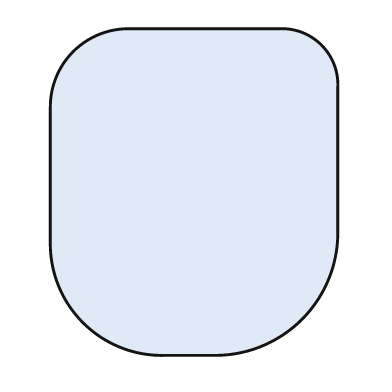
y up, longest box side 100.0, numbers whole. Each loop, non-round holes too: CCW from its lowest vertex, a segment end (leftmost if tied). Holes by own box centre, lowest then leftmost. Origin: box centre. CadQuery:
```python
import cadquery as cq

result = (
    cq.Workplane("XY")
    .moveTo(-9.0, -50.0)
    .lineTo(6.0, -50.0)
    .threePointArc((33.0, -39.0), (44.0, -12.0))
    .lineTo(44.0, 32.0)
    .threePointArc((39.0, 45.0), (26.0, 50.0))
    .lineTo(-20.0, 50.0)
    .threePointArc((-37.0, 43.0), (-44.0, 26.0))
    .lineTo(-44.0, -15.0)
    .threePointArc((-34.0, -40.0), (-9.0, -50.0))
    .close()
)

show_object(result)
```